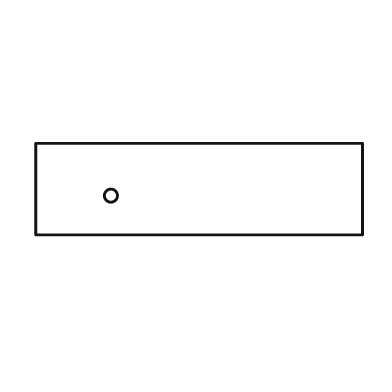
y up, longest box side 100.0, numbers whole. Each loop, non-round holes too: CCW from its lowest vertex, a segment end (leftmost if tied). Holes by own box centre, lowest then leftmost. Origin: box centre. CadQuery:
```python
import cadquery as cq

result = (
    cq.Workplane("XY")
    .moveTo(-50.0, -14.0)
    .lineTo(50.0, -14.0)
    .lineTo(50.0, 14.0)
    .lineTo(-50.0, 14.0)
    .close()
    .moveTo(-27.0, -2.0)
    .circle(2.0)
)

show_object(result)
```